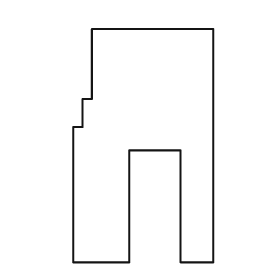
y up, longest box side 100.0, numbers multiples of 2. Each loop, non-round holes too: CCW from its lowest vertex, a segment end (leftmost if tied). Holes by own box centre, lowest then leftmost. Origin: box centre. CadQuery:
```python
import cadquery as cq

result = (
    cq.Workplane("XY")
    .moveTo(-30.0, -50.0)
    .lineTo(-6.0, -50.0)
    .lineTo(-6.0, -2.0)
    .lineTo(16.0, -2.0)
    .lineTo(16.0, -50.0)
    .lineTo(30.0, -50.0)
    .lineTo(30.0, 50.0)
    .lineTo(-22.0, 50.0)
    .lineTo(-22.0, 20.0)
    .lineTo(-26.0, 20.0)
    .lineTo(-26.0, 8.0)
    .lineTo(-30.0, 8.0)
    .close()
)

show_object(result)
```